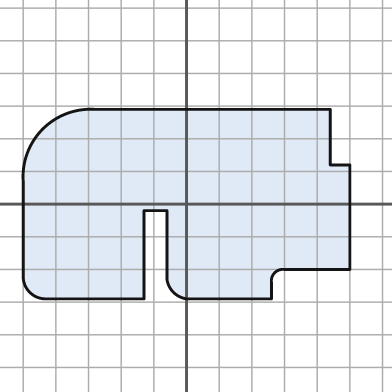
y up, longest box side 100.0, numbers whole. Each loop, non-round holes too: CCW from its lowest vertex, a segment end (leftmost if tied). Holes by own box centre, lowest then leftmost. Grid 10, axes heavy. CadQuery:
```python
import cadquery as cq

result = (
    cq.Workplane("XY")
    .moveTo(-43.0, -29.0)
    .lineTo(-13.0, -29.0)
    .lineTo(-13.0, -2.0)
    .lineTo(-6.0, -2.0)
    .lineTo(-6.0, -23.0)
    .threePointArc((-4.0, -27.0), (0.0, -29.0))
    .lineTo(26.0, -29.0)
    .lineTo(26.0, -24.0)
    .threePointArc((27.0, -21.0), (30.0, -20.0))
    .lineTo(50.0, -20.0)
    .lineTo(50.0, 12.0)
    .lineTo(44.0, 12.0)
    .lineTo(44.0, 29.0)
    .lineTo(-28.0, 29.0)
    .threePointArc((-44.0, 23.0), (-50.0, 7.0))
    .lineTo(-50.0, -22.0)
    .threePointArc((-48.0, -27.0), (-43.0, -29.0))
    .close()
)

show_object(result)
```